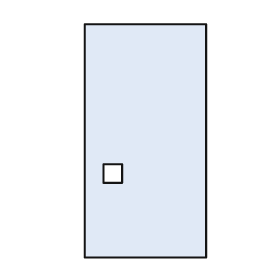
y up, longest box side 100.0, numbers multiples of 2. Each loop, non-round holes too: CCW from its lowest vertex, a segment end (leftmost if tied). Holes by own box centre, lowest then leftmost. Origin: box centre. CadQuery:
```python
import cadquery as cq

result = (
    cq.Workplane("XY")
    .moveTo(-26.0, -50.0)
    .lineTo(26.0, -50.0)
    .lineTo(26.0, 50.0)
    .lineTo(-26.0, 50.0)
    .close()
    .moveTo(-18.0, -18.0)
    .lineTo(-10.0, -18.0)
    .lineTo(-10.0, -10.0)
    .lineTo(-18.0, -10.0)
    .close()
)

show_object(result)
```